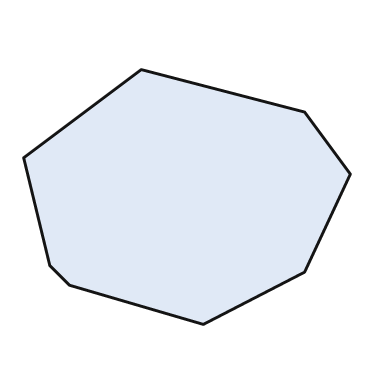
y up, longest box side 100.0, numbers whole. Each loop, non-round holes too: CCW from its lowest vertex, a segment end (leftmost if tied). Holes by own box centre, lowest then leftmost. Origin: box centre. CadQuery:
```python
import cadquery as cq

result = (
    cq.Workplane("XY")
    .moveTo(5.0, -39.0)
    .lineTo(36.0, -23.0)
    .lineTo(50.0, 7.0)
    .lineTo(36.0, 26.0)
    .lineTo(-14.0, 39.0)
    .lineTo(-50.0, 12.0)
    .lineTo(-42.0, -21.0)
    .lineTo(-36.0, -27.0)
    .close()
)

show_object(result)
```